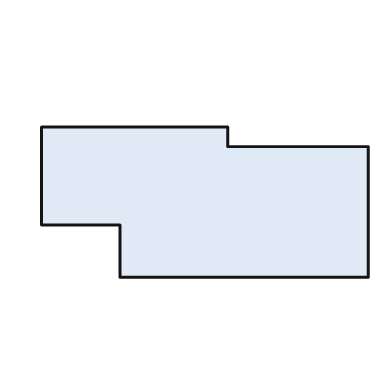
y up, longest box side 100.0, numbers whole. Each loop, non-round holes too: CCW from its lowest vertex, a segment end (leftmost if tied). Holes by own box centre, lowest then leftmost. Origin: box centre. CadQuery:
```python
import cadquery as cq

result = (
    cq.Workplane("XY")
    .moveTo(-26.0, -23.0)
    .lineTo(50.0, -23.0)
    .lineTo(50.0, 17.0)
    .lineTo(7.0, 17.0)
    .lineTo(7.0, 23.0)
    .lineTo(-50.0, 23.0)
    .lineTo(-50.0, -7.0)
    .lineTo(-26.0, -7.0)
    .close()
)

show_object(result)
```